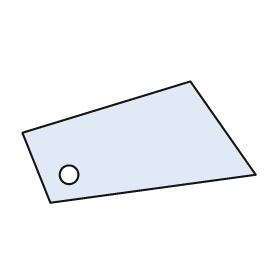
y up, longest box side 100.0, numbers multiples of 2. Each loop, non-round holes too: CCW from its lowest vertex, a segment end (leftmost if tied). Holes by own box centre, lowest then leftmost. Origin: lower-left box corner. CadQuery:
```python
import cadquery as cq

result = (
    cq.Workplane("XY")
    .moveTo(12.0, 0.0)
    .lineTo(100.0, 12.0)
    .lineTo(72.0, 52.0)
    .lineTo(0.0, 30.0)
    .close()
    .moveTo(20.0, 12.0)
    .circle(4.0)
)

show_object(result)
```